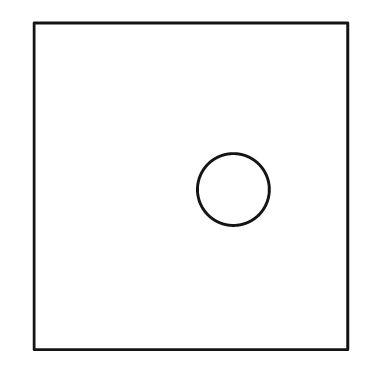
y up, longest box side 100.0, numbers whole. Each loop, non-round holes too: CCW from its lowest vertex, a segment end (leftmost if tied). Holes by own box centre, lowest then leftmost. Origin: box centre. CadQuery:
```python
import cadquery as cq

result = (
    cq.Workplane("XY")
    .moveTo(-48.0, -50.0)
    .lineTo(48.0, -50.0)
    .lineTo(48.0, 50.0)
    .lineTo(-48.0, 50.0)
    .close()
    .moveTo(13.0, -1.0)
    .circle(11.0)
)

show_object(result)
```